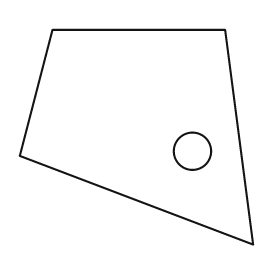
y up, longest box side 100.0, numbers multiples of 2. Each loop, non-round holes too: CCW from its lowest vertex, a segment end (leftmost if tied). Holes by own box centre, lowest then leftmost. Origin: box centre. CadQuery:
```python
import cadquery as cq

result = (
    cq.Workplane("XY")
    .moveTo(50.0, -46.0)
    .lineTo(38.0, 46.0)
    .lineTo(-36.0, 46.0)
    .lineTo(-50.0, -8.0)
    .close()
    .moveTo(24.0, -6.0)
    .circle(8.0)
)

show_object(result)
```